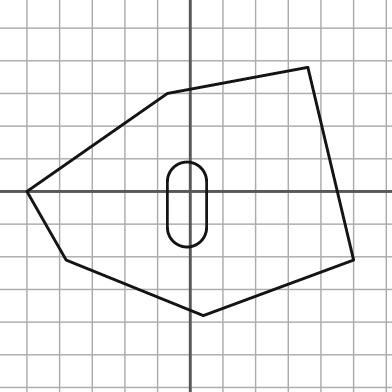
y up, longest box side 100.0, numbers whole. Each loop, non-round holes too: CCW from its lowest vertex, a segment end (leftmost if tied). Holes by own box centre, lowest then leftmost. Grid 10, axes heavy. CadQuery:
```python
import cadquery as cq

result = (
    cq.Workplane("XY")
    .moveTo(4.0, -38.0)
    .lineTo(50.0, -21.0)
    .lineTo(36.0, 38.0)
    .lineTo(-7.0, 30.0)
    .lineTo(-50.0, 0.0)
    .lineTo(-38.0, -21.0)
    .close()
    .moveTo(-7.0, -11.0)
    .threePointArc((-1.0, -17.0), (5.0, -11.0))
    .lineTo(5.0, 3.0)
    .threePointArc((-1.0, 9.0), (-7.0, 3.0))
    .close()
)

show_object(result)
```